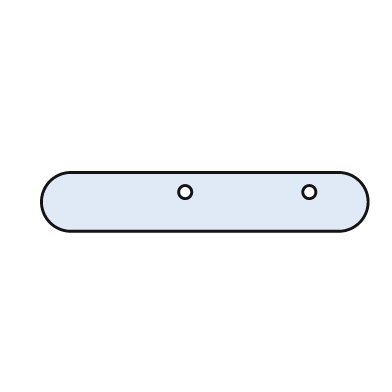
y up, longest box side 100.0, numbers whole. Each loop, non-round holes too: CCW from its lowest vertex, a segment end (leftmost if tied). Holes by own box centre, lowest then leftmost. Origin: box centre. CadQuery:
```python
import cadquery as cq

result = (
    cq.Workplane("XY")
    .moveTo(-41.0, -9.0)
    .lineTo(41.0, -9.0)
    .threePointArc((50.0, 0.0), (41.0, 9.0))
    .lineTo(-41.0, 9.0)
    .threePointArc((-50.0, 0.0), (-41.0, -9.0))
    .close()
    .moveTo(-6.0, 3.0)
    .circle(2.0)
    .moveTo(32.0, 3.0)
    .circle(2.0)
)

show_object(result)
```